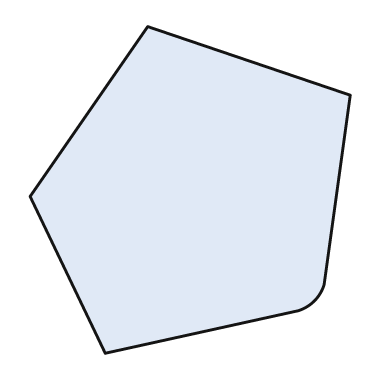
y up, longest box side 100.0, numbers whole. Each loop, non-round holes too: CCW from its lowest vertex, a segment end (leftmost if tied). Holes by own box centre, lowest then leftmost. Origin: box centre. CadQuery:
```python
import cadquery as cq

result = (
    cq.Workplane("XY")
    .moveTo(-26.0, -50.0)
    .lineTo(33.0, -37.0)
    .threePointArc((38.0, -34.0), (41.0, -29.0))
    .lineTo(49.0, 29.0)
    .lineTo(-13.0, 50.0)
    .lineTo(-49.0, -2.0)
    .close()
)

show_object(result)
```